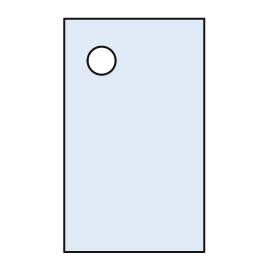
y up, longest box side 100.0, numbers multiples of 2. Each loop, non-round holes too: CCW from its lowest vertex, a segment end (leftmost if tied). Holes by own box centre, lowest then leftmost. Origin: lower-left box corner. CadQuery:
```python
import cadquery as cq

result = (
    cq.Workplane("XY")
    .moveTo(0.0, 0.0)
    .lineTo(60.0, 0.0)
    .lineTo(60.0, 100.0)
    .lineTo(0.0, 100.0)
    .close()
    .moveTo(16.0, 82.0)
    .circle(6.0)
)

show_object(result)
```